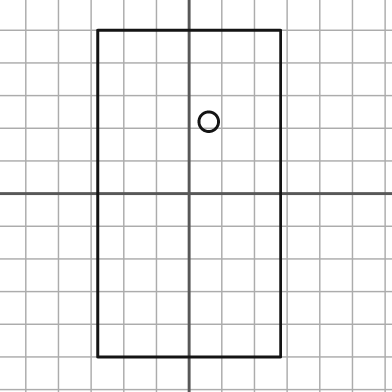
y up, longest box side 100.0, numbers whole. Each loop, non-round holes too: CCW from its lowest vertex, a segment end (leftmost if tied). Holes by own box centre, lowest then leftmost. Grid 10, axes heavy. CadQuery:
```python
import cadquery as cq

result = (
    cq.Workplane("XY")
    .moveTo(-28.0, -50.0)
    .lineTo(28.0, -50.0)
    .lineTo(28.0, 50.0)
    .lineTo(-28.0, 50.0)
    .close()
    .moveTo(6.0, 22.0)
    .circle(3.0)
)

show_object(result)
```